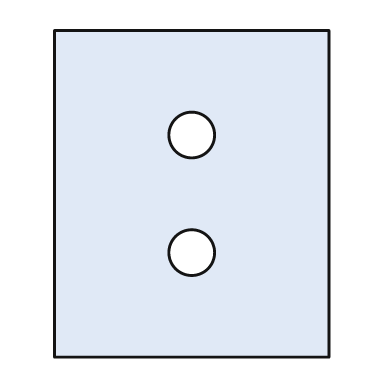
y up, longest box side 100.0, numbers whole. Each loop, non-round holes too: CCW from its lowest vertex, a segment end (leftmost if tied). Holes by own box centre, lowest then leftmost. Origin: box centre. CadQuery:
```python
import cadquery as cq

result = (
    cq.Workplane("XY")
    .moveTo(-42.0, -50.0)
    .lineTo(42.0, -50.0)
    .lineTo(42.0, 50.0)
    .lineTo(-42.0, 50.0)
    .close()
    .moveTo(0.0, -18.0)
    .circle(7.0)
    .moveTo(0.0, 18.0)
    .circle(7.0)
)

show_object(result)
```